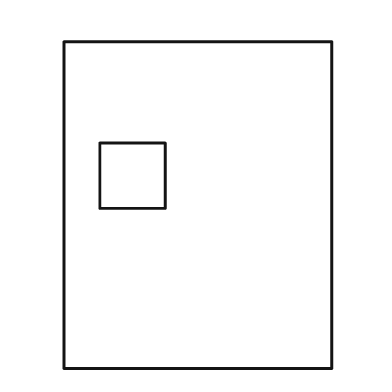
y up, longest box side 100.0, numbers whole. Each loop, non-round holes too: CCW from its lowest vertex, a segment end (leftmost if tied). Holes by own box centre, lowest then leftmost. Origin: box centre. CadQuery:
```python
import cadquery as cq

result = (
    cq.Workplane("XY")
    .moveTo(-41.0, -50.0)
    .lineTo(41.0, -50.0)
    .lineTo(41.0, 50.0)
    .lineTo(-41.0, 50.0)
    .close()
    .moveTo(-30.0, -1.0)
    .lineTo(-10.0, -1.0)
    .lineTo(-10.0, 19.0)
    .lineTo(-30.0, 19.0)
    .close()
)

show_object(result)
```